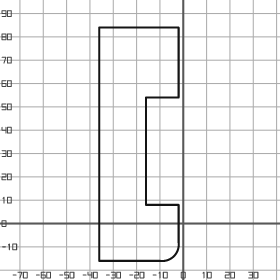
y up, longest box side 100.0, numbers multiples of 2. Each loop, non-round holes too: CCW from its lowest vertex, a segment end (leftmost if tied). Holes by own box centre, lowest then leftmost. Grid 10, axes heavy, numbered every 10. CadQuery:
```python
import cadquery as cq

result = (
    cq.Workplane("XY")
    .moveTo(-36.0, -16.0)
    .lineTo(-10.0, -16.0)
    .threePointArc((-4.0, -14.0), (-2.0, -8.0))
    .lineTo(-2.0, 8.0)
    .lineTo(-16.0, 8.0)
    .lineTo(-16.0, 54.0)
    .lineTo(-2.0, 54.0)
    .lineTo(-2.0, 84.0)
    .lineTo(-36.0, 84.0)
    .close()
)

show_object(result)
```